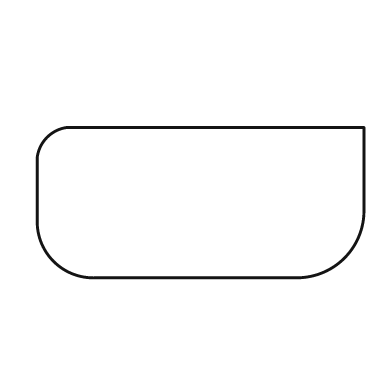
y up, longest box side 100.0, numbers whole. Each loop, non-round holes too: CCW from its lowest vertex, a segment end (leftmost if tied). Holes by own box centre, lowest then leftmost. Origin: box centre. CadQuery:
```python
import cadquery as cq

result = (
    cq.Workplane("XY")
    .moveTo(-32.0, -23.0)
    .lineTo(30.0, -23.0)
    .threePointArc((44.0, -17.0), (50.0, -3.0))
    .lineTo(50.0, 23.0)
    .lineTo(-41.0, 23.0)
    .threePointArc((-47.0, 20.0), (-50.0, 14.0))
    .lineTo(-50.0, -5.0)
    .threePointArc((-45.0, -18.0), (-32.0, -23.0))
    .close()
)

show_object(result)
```